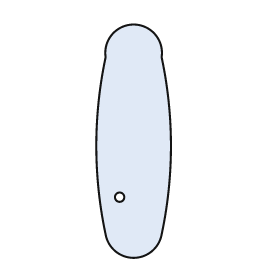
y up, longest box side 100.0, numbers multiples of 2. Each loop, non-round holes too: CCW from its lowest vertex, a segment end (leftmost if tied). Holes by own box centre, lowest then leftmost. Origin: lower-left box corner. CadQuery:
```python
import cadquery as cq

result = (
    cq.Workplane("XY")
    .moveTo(4.0, 10.0)
    .threePointArc((16.0, 0.0), (28.0, 10.0))
    .threePointArc((32.0, 48.0), (28.0, 86.0))
    .threePointArc((16.0, 100.0), (4.0, 86.0))
    .threePointArc((0.0, 48.0), (4.0, 10.0))
    .close()
    .moveTo(10.0, 26.0)
    .circle(2.0)
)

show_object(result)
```